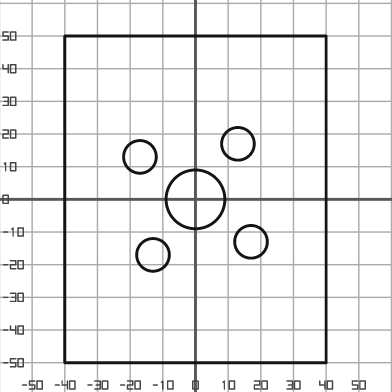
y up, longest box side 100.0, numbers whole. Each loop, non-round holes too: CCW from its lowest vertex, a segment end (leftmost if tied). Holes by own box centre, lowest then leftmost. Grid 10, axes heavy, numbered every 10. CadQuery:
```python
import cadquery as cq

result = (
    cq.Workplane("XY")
    .moveTo(-40.0, -50.0)
    .lineTo(40.0, -50.0)
    .lineTo(40.0, 50.0)
    .lineTo(-40.0, 50.0)
    .close()
    .moveTo(-13.0, -17.0)
    .circle(5.0)
    .moveTo(17.0, -13.0)
    .circle(5.0)
    .moveTo(0.0, 0.0)
    .circle(9.0)
    .moveTo(-17.0, 13.0)
    .circle(5.0)
    .moveTo(13.0, 17.0)
    .circle(5.0)
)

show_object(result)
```